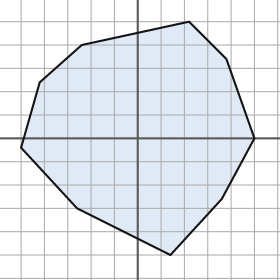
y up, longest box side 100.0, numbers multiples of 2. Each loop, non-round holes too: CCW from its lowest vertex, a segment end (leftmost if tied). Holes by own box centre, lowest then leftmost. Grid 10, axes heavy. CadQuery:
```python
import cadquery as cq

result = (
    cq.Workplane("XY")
    .moveTo(14.0, -50.0)
    .lineTo(36.0, -26.0)
    .lineTo(50.0, 0.0)
    .lineTo(38.0, 34.0)
    .lineTo(22.0, 50.0)
    .lineTo(-24.0, 40.0)
    .lineTo(-42.0, 24.0)
    .lineTo(-50.0, -4.0)
    .lineTo(-26.0, -30.0)
    .close()
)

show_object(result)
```